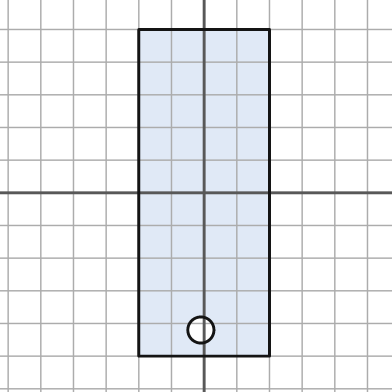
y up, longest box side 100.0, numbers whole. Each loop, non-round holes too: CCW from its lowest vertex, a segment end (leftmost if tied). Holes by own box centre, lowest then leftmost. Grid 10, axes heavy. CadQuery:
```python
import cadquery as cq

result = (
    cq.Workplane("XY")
    .moveTo(-20.0, -50.0)
    .lineTo(20.0, -50.0)
    .lineTo(20.0, 50.0)
    .lineTo(-20.0, 50.0)
    .close()
    .moveTo(-1.0, -42.0)
    .circle(4.0)
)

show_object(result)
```